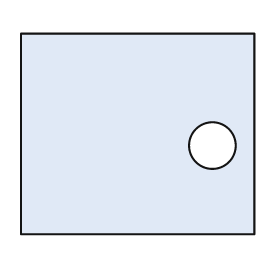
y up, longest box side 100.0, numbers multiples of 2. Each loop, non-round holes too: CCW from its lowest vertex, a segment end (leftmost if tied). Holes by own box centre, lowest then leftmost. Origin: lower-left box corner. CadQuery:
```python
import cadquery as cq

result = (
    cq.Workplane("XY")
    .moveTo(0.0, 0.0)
    .lineTo(100.0, 0.0)
    .lineTo(100.0, 86.0)
    .lineTo(0.0, 86.0)
    .close()
    .moveTo(82.0, 38.0)
    .circle(10.0)
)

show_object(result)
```